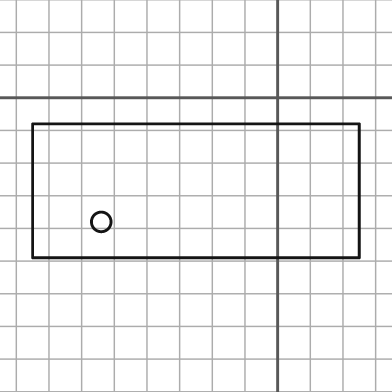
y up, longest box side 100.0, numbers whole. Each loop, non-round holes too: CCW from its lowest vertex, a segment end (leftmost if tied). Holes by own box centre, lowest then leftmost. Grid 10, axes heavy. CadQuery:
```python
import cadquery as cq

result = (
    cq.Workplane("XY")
    .moveTo(-75.0, -49.0)
    .lineTo(25.0, -49.0)
    .lineTo(25.0, -8.0)
    .lineTo(-75.0, -8.0)
    .close()
    .moveTo(-54.0, -38.0)
    .circle(3.0)
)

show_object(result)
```